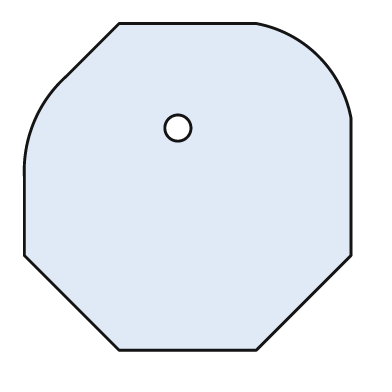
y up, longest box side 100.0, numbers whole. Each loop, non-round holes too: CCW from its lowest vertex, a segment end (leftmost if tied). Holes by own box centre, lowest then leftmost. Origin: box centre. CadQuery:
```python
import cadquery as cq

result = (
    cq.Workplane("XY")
    .moveTo(-21.0, -50.0)
    .lineTo(21.0, -50.0)
    .lineTo(50.0, -21.0)
    .lineTo(50.0, 21.0)
    .threePointArc((40.0, 40.0), (21.0, 50.0))
    .lineTo(-21.0, 50.0)
    .lineTo(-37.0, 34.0)
    .threePointArc((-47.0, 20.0), (-50.0, 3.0))
    .lineTo(-50.0, -21.0)
    .close()
    .moveTo(-3.0, 18.0)
    .circle(4.0)
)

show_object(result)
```